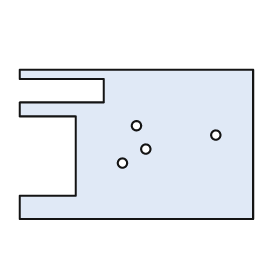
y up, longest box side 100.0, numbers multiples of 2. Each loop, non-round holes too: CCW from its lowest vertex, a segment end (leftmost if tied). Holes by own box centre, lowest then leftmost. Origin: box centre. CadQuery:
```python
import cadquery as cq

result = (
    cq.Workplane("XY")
    .moveTo(-50.0, -32.0)
    .lineTo(50.0, -32.0)
    .lineTo(50.0, 32.0)
    .lineTo(-50.0, 32.0)
    .lineTo(-50.0, 28.0)
    .lineTo(-14.0, 28.0)
    .lineTo(-14.0, 18.0)
    .lineTo(-50.0, 18.0)
    .lineTo(-50.0, 12.0)
    .lineTo(-26.0, 12.0)
    .lineTo(-26.0, -22.0)
    .lineTo(-50.0, -22.0)
    .close()
    .moveTo(-6.0, -8.0)
    .circle(2.0)
    .moveTo(4.0, -2.0)
    .circle(2.0)
    .moveTo(34.0, 4.0)
    .circle(2.0)
    .moveTo(0.0, 8.0)
    .circle(2.0)
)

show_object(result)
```